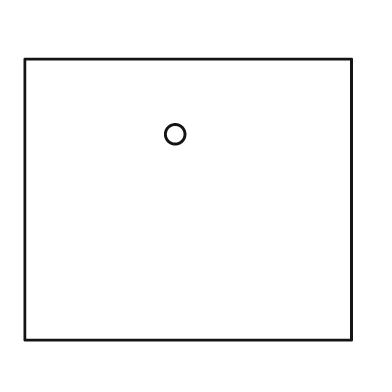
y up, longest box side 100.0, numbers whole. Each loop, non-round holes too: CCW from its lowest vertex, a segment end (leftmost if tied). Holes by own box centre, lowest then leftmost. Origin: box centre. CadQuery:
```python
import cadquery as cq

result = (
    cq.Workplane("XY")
    .moveTo(-50.0, -43.0)
    .lineTo(50.0, -43.0)
    .lineTo(50.0, 43.0)
    .lineTo(-50.0, 43.0)
    .close()
    .moveTo(-4.0, 20.0)
    .circle(3.0)
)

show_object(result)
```